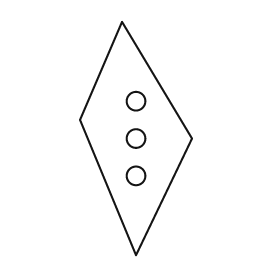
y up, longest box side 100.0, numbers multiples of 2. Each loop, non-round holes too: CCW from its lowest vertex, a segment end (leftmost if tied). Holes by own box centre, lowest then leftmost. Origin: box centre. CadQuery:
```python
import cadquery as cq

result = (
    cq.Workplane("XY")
    .moveTo(0.0, -50.0)
    .lineTo(24.0, 0.0)
    .lineTo(-6.0, 50.0)
    .lineTo(-24.0, 8.0)
    .close()
    .moveTo(0.0, -16.0)
    .circle(4.0)
    .moveTo(0.0, 0.0)
    .circle(4.0)
    .moveTo(0.0, 16.0)
    .circle(4.0)
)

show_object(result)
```